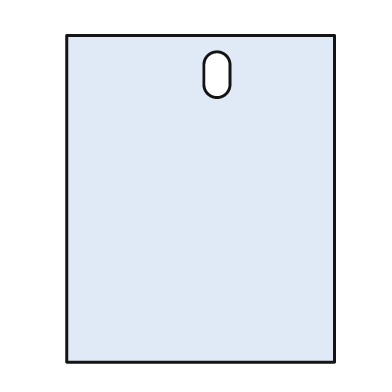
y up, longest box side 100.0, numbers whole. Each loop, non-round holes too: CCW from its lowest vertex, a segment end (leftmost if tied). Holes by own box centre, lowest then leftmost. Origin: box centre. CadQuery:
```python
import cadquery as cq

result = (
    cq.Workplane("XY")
    .moveTo(-41.0, -50.0)
    .lineTo(41.0, -50.0)
    .lineTo(41.0, 50.0)
    .lineTo(-41.0, 50.0)
    .close()
    .moveTo(1.0, 35.0)
    .threePointArc((5.0, 31.0), (9.0, 35.0))
    .lineTo(9.0, 41.0)
    .threePointArc((5.0, 45.0), (1.0, 41.0))
    .close()
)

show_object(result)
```